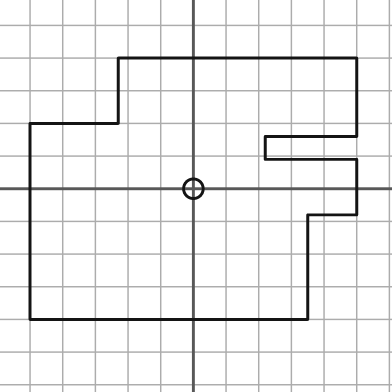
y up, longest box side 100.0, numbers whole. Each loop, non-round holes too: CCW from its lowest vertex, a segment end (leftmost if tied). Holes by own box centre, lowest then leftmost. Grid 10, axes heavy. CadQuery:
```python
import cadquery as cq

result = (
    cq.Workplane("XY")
    .moveTo(-50.0, -40.0)
    .lineTo(35.0, -40.0)
    .lineTo(35.0, -8.0)
    .lineTo(50.0, -8.0)
    .lineTo(50.0, 9.0)
    .lineTo(22.0, 9.0)
    .lineTo(22.0, 16.0)
    .lineTo(50.0, 16.0)
    .lineTo(50.0, 40.0)
    .lineTo(-23.0, 40.0)
    .lineTo(-23.0, 20.0)
    .lineTo(-50.0, 20.0)
    .close()
    .moveTo(0.0, 0.0)
    .circle(3.0)
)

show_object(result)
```